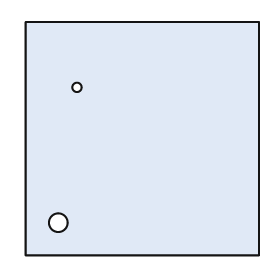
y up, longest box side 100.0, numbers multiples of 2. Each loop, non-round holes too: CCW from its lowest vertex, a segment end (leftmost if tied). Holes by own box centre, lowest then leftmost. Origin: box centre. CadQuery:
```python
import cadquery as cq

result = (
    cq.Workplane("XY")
    .moveTo(-50.0, -50.0)
    .lineTo(50.0, -50.0)
    .lineTo(50.0, 50.0)
    .lineTo(-50.0, 50.0)
    .close()
    .moveTo(-36.0, -36.0)
    .circle(4.0)
    .moveTo(-28.0, 22.0)
    .circle(2.0)
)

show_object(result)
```